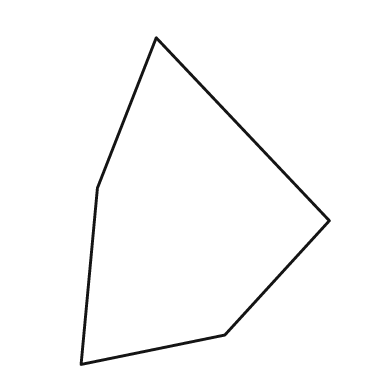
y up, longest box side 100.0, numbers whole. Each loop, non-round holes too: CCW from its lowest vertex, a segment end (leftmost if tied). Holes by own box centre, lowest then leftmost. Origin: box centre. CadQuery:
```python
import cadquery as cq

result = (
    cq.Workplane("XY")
    .moveTo(-38.0, -50.0)
    .lineTo(6.0, -41.0)
    .lineTo(38.0, -6.0)
    .lineTo(-15.0, 50.0)
    .lineTo(-33.0, 4.0)
    .close()
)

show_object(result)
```